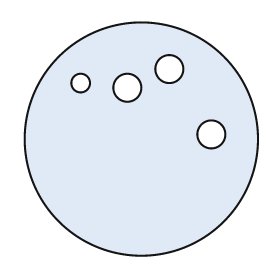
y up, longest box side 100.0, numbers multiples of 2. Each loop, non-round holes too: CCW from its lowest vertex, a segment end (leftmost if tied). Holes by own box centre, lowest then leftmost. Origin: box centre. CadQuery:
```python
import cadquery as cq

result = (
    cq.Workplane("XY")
    .moveTo(0.0, 0.0)
    .circle(50.0)
    .moveTo(30.0, 2.0)
    .circle(6.0)
    .moveTo(-6.0, 22.0)
    .circle(6.0)
    .moveTo(-26.0, 24.0)
    .circle(4.0)
    .moveTo(12.0, 30.0)
    .circle(6.0)
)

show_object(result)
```